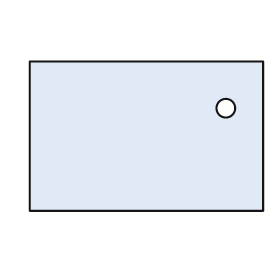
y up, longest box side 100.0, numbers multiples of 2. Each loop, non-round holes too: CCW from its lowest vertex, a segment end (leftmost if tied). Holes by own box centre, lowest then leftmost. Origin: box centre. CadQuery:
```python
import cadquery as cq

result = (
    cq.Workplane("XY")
    .moveTo(-50.0, -32.0)
    .lineTo(50.0, -32.0)
    .lineTo(50.0, 32.0)
    .lineTo(-50.0, 32.0)
    .close()
    .moveTo(34.0, 12.0)
    .circle(4.0)
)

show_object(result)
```